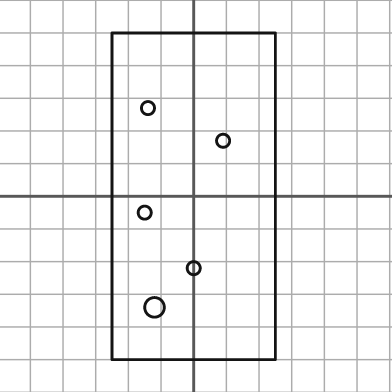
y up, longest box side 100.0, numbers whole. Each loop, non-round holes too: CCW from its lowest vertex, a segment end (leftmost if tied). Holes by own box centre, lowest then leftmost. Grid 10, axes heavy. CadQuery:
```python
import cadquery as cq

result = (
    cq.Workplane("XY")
    .moveTo(-25.0, -50.0)
    .lineTo(25.0, -50.0)
    .lineTo(25.0, 50.0)
    .lineTo(-25.0, 50.0)
    .close()
    .moveTo(-12.0, -34.0)
    .circle(3.0)
    .moveTo(0.0, -22.0)
    .circle(2.0)
    .moveTo(-15.0, -5.0)
    .circle(2.0)
    .moveTo(9.0, 17.0)
    .circle(2.0)
    .moveTo(-14.0, 27.0)
    .circle(2.0)
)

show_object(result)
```